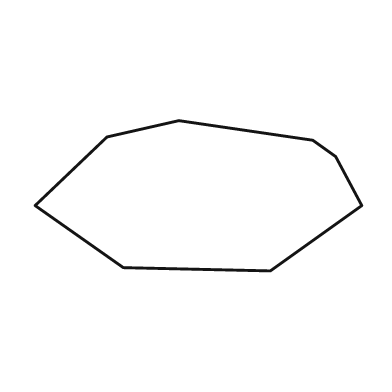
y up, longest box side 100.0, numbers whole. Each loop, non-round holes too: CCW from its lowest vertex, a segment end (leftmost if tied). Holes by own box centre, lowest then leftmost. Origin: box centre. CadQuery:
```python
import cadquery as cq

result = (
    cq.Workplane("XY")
    .moveTo(22.0, -23.0)
    .lineTo(50.0, -3.0)
    .lineTo(42.0, 12.0)
    .lineTo(35.0, 17.0)
    .lineTo(-6.0, 23.0)
    .lineTo(-28.0, 18.0)
    .lineTo(-50.0, -3.0)
    .lineTo(-23.0, -22.0)
    .close()
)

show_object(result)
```